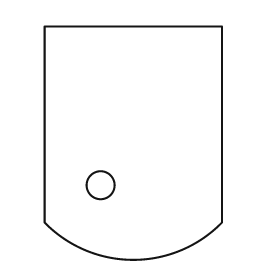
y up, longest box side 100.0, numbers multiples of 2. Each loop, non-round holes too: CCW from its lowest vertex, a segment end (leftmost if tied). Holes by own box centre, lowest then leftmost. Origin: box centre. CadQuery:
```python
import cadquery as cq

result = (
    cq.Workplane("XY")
    .moveTo(-38.0, -34.0)
    .threePointArc((0.0, -50.0), (38.0, -34.0))
    .lineTo(38.0, 50.0)
    .lineTo(-38.0, 50.0)
    .close()
    .moveTo(-14.0, -18.0)
    .circle(6.0)
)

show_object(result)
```